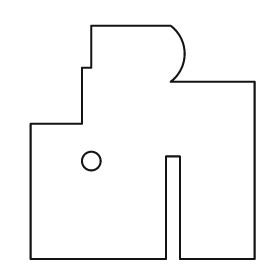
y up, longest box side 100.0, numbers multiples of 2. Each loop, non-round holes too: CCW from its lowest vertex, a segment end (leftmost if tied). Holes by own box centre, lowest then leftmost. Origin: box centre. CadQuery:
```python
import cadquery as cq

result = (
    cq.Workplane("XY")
    .moveTo(-48.0, -50.0)
    .lineTo(10.0, -50.0)
    .lineTo(10.0, -6.0)
    .lineTo(16.0, -6.0)
    .lineTo(16.0, -50.0)
    .lineTo(48.0, -50.0)
    .lineTo(48.0, 26.0)
    .lineTo(12.0, 26.0)
    .threePointArc((18.0, 38.0), (12.0, 50.0))
    .lineTo(-22.0, 50.0)
    .lineTo(-22.0, 32.0)
    .lineTo(-26.0, 32.0)
    .lineTo(-26.0, 8.0)
    .lineTo(-48.0, 8.0)
    .close()
    .moveTo(-22.0, -8.0)
    .circle(4.0)
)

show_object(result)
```